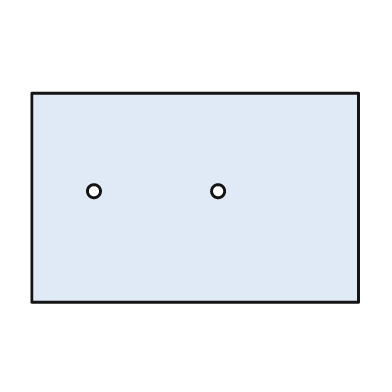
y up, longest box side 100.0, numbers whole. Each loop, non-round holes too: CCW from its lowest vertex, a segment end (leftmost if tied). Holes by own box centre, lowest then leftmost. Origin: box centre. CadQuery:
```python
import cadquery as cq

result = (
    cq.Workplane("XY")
    .moveTo(-50.0, -32.0)
    .lineTo(50.0, -32.0)
    .lineTo(50.0, 32.0)
    .lineTo(-50.0, 32.0)
    .close()
    .moveTo(-31.0, 2.0)
    .circle(2.0)
    .moveTo(7.0, 2.0)
    .circle(2.0)
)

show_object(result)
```